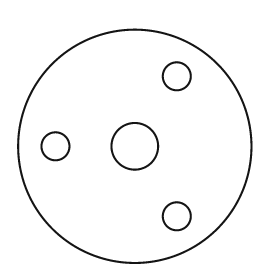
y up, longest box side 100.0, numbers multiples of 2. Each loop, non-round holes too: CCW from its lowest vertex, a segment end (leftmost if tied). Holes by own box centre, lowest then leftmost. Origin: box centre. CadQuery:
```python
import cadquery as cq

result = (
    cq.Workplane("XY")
    .moveTo(0.0, 0.0)
    .circle(50.0)
    .moveTo(18.0, -30.0)
    .circle(6.0)
    .moveTo(-34.0, 0.0)
    .circle(6.0)
    .moveTo(0.0, 0.0)
    .circle(10.0)
    .moveTo(18.0, 30.0)
    .circle(6.0)
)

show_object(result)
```